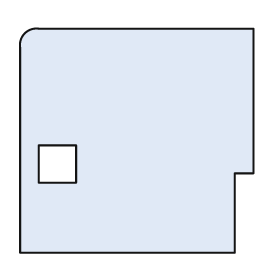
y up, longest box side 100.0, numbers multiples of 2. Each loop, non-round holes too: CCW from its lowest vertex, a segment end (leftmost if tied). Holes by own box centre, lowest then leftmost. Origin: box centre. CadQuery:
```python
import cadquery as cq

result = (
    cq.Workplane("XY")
    .moveTo(-50.0, -48.0)
    .lineTo(42.0, -48.0)
    .lineTo(42.0, -14.0)
    .lineTo(50.0, -14.0)
    .lineTo(50.0, 48.0)
    .lineTo(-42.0, 48.0)
    .threePointArc((-48.0, 46.0), (-50.0, 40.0))
    .close()
    .moveTo(-42.0, -18.0)
    .lineTo(-26.0, -18.0)
    .lineTo(-26.0, -2.0)
    .lineTo(-42.0, -2.0)
    .close()
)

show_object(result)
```